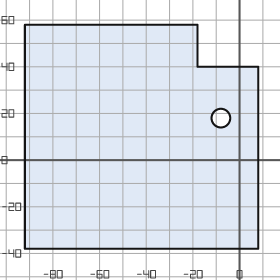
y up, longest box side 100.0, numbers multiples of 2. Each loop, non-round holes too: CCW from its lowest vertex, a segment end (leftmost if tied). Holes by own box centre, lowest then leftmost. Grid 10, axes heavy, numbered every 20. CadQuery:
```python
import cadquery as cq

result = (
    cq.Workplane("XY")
    .moveTo(-92.0, -38.0)
    .lineTo(8.0, -38.0)
    .lineTo(8.0, 40.0)
    .lineTo(-18.0, 40.0)
    .lineTo(-18.0, 58.0)
    .lineTo(-92.0, 58.0)
    .close()
    .moveTo(-8.0, 18.0)
    .circle(4.0)
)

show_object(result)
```